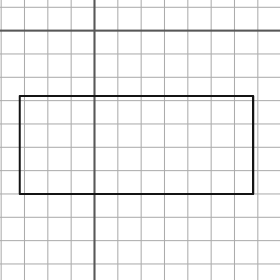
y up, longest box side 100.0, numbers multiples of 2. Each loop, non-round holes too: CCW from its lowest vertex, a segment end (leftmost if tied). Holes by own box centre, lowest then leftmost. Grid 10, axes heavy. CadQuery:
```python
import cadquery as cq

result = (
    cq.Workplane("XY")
    .moveTo(-32.0, -70.0)
    .lineTo(68.0, -70.0)
    .lineTo(68.0, -28.0)
    .lineTo(-32.0, -28.0)
    .close()
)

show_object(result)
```